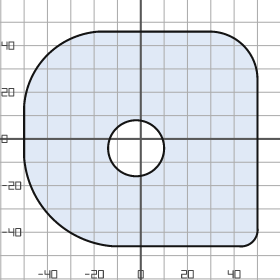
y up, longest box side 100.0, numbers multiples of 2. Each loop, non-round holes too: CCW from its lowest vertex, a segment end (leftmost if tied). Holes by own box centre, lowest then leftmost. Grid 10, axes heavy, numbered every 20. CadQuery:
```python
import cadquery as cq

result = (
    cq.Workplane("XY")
    .moveTo(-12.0, -46.0)
    .lineTo(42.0, -46.0)
    .threePointArc((48.0, -44.0), (50.0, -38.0))
    .lineTo(50.0, 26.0)
    .threePointArc((44.0, 40.0), (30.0, 46.0))
    .lineTo(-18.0, 46.0)
    .threePointArc((-40.0, 36.0), (-50.0, 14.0))
    .lineTo(-50.0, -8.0)
    .threePointArc((-38.0, -34.0), (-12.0, -46.0))
    .close()
    .moveTo(-2.0, -4.0)
    .circle(12.0)
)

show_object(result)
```